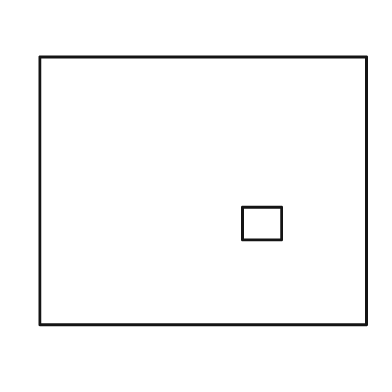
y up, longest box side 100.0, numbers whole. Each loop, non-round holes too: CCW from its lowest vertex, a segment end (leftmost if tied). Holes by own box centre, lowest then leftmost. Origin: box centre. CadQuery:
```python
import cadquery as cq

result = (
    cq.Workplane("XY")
    .moveTo(-50.0, -41.0)
    .lineTo(50.0, -41.0)
    .lineTo(50.0, 41.0)
    .lineTo(-50.0, 41.0)
    .close()
    .moveTo(12.0, -15.0)
    .lineTo(24.0, -15.0)
    .lineTo(24.0, -5.0)
    .lineTo(12.0, -5.0)
    .close()
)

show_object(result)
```